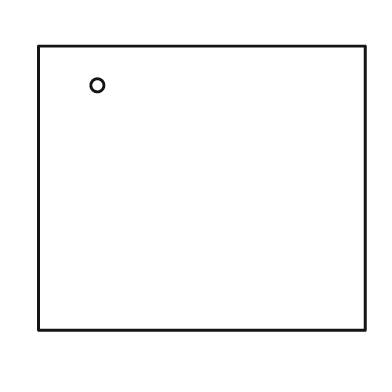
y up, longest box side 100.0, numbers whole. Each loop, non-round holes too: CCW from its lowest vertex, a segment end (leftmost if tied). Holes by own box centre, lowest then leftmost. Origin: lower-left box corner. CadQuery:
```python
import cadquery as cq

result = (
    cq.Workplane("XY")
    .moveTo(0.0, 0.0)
    .lineTo(100.0, 0.0)
    .lineTo(100.0, 87.0)
    .lineTo(0.0, 87.0)
    .close()
    .moveTo(18.0, 75.0)
    .circle(2.0)
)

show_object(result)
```